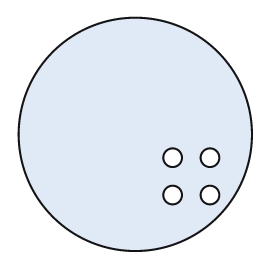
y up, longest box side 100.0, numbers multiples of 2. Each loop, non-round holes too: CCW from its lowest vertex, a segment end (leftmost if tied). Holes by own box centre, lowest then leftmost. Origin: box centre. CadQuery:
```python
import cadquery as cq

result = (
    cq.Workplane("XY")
    .moveTo(0.0, 0.0)
    .circle(50.0)
    .moveTo(16.0, -26.0)
    .circle(4.0)
    .moveTo(32.0, -26.0)
    .circle(4.0)
    .moveTo(16.0, -10.0)
    .circle(4.0)
    .moveTo(32.0, -10.0)
    .circle(4.0)
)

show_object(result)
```